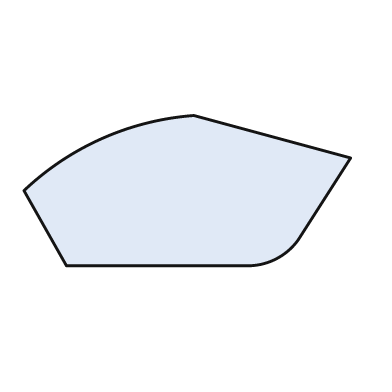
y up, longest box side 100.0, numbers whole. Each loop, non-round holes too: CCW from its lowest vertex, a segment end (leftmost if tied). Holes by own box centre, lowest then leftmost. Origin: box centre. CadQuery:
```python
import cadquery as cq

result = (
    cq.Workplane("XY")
    .moveTo(-37.0, -23.0)
    .lineTo(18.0, -23.0)
    .threePointArc((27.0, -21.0), (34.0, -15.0))
    .lineTo(50.0, 10.0)
    .lineTo(2.0, 23.0)
    .threePointArc((-26.0, 16.0), (-50.0, 0.0))
    .close()
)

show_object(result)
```